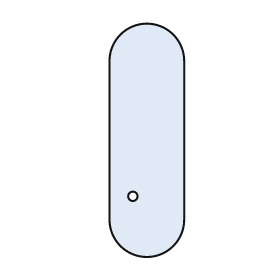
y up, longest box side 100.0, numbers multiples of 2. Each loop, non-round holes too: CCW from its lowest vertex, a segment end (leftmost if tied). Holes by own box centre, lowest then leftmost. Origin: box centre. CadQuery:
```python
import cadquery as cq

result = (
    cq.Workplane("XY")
    .moveTo(-16.0, -34.0)
    .threePointArc((0.0, -50.0), (16.0, -34.0))
    .lineTo(16.0, 34.0)
    .threePointArc((0.0, 50.0), (-16.0, 34.0))
    .close()
    .moveTo(-6.0, -24.0)
    .circle(2.0)
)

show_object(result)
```